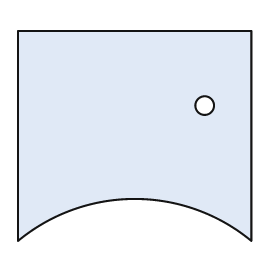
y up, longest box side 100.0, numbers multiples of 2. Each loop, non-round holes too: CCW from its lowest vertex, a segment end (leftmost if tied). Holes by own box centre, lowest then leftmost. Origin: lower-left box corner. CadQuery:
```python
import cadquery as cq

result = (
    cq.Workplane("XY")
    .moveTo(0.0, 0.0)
    .threePointArc((50.0, 18.0), (100.0, 0.0))
    .lineTo(100.0, 90.0)
    .lineTo(0.0, 90.0)
    .close()
    .moveTo(80.0, 58.0)
    .circle(4.0)
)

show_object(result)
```